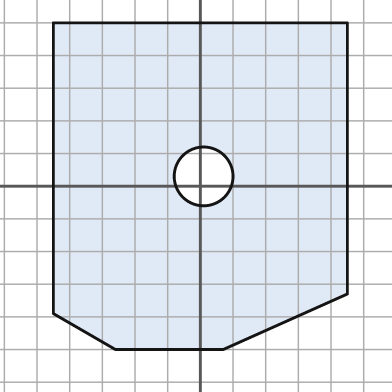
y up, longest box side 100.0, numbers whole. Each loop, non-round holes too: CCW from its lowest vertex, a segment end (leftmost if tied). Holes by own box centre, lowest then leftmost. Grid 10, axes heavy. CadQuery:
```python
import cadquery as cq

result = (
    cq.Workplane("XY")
    .moveTo(-26.0, -50.0)
    .lineTo(7.0, -50.0)
    .lineTo(45.0, -33.0)
    .lineTo(45.0, 50.0)
    .lineTo(-45.0, 50.0)
    .lineTo(-45.0, -39.0)
    .close()
    .moveTo(1.0, 3.0)
    .circle(9.0)
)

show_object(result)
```